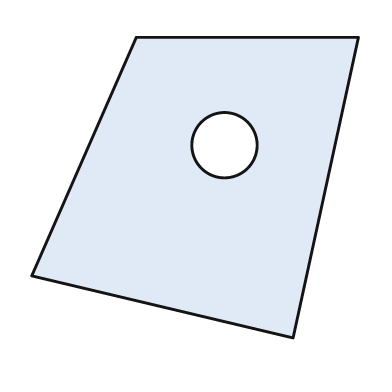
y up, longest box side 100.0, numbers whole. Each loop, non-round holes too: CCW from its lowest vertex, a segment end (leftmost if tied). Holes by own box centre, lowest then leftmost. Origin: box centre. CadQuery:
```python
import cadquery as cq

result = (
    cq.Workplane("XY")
    .moveTo(30.0, -46.0)
    .lineTo(50.0, 46.0)
    .lineTo(-18.0, 46.0)
    .lineTo(-50.0, -27.0)
    .close()
    .moveTo(9.0, 13.0)
    .circle(10.0)
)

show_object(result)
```